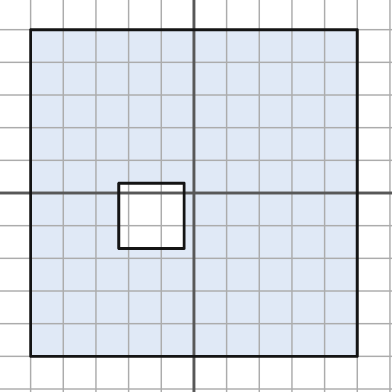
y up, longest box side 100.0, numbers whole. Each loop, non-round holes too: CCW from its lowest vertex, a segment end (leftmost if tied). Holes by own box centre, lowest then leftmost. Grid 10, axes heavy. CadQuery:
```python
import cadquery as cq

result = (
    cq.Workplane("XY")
    .moveTo(-50.0, -50.0)
    .lineTo(50.0, -50.0)
    .lineTo(50.0, 50.0)
    .lineTo(-50.0, 50.0)
    .close()
    .moveTo(-23.0, -17.0)
    .lineTo(-3.0, -17.0)
    .lineTo(-3.0, 3.0)
    .lineTo(-23.0, 3.0)
    .close()
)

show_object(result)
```